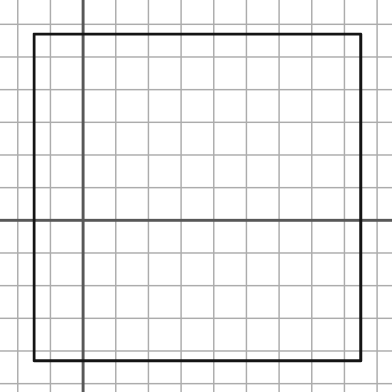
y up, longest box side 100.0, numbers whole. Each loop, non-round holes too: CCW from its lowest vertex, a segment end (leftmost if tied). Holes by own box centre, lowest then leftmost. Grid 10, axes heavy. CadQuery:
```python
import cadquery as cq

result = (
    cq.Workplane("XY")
    .moveTo(-15.0, -43.0)
    .lineTo(85.0, -43.0)
    .lineTo(85.0, 57.0)
    .lineTo(-15.0, 57.0)
    .close()
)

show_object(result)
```